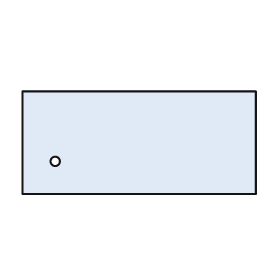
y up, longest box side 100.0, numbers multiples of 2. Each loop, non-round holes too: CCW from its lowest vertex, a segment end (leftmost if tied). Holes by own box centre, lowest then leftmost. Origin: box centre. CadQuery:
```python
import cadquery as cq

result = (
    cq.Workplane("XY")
    .moveTo(-50.0, -22.0)
    .lineTo(50.0, -22.0)
    .lineTo(50.0, 22.0)
    .lineTo(-50.0, 22.0)
    .close()
    .moveTo(-36.0, -8.0)
    .circle(2.0)
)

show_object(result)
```